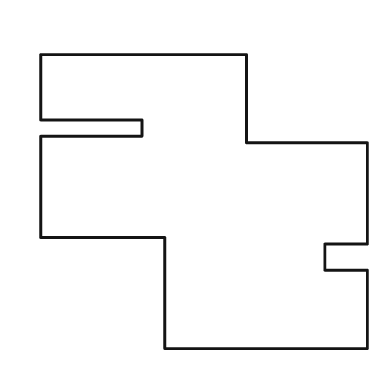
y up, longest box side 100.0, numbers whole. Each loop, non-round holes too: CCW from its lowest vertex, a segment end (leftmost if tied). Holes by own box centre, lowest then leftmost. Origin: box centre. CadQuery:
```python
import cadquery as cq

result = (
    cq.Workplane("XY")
    .moveTo(-12.0, -45.0)
    .lineTo(50.0, -45.0)
    .lineTo(50.0, -21.0)
    .lineTo(37.0, -21.0)
    .lineTo(37.0, -13.0)
    .lineTo(50.0, -13.0)
    .lineTo(50.0, 18.0)
    .lineTo(13.0, 18.0)
    .lineTo(13.0, 45.0)
    .lineTo(-50.0, 45.0)
    .lineTo(-50.0, 25.0)
    .lineTo(-19.0, 25.0)
    .lineTo(-19.0, 20.0)
    .lineTo(-50.0, 20.0)
    .lineTo(-50.0, -11.0)
    .lineTo(-12.0, -11.0)
    .close()
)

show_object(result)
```